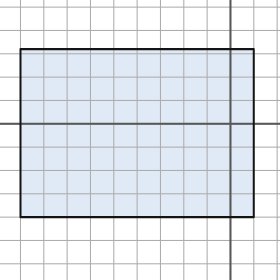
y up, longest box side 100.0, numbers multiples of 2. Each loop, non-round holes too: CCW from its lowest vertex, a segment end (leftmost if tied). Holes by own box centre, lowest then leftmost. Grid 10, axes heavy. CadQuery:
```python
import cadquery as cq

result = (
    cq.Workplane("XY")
    .moveTo(-90.0, -40.0)
    .lineTo(10.0, -40.0)
    .lineTo(10.0, 32.0)
    .lineTo(-90.0, 32.0)
    .close()
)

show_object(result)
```